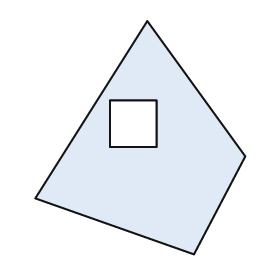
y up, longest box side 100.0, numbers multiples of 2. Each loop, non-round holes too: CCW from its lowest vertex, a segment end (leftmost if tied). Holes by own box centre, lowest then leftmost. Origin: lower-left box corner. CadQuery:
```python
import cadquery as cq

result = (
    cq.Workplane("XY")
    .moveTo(68.0, 0.0)
    .lineTo(90.0, 42.0)
    .lineTo(48.0, 100.0)
    .lineTo(0.0, 24.0)
    .close()
    .moveTo(32.0, 46.0)
    .lineTo(52.0, 46.0)
    .lineTo(52.0, 66.0)
    .lineTo(32.0, 66.0)
    .close()
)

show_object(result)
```